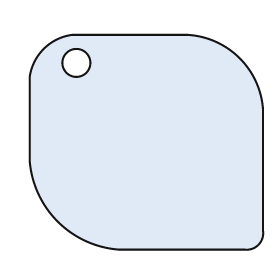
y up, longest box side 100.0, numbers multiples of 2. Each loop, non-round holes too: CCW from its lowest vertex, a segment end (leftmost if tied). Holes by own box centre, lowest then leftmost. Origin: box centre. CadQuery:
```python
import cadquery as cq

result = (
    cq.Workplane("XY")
    .moveTo(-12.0, -46.0)
    .lineTo(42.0, -46.0)
    .threePointArc((48.0, -44.0), (50.0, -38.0))
    .lineTo(50.0, 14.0)
    .threePointArc((40.0, 36.0), (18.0, 46.0))
    .lineTo(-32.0, 46.0)
    .threePointArc((-44.0, 40.0), (-50.0, 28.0))
    .lineTo(-50.0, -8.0)
    .threePointArc((-38.0, -34.0), (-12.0, -46.0))
    .close()
    .moveTo(-30.0, 34.0)
    .circle(6.0)
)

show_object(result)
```